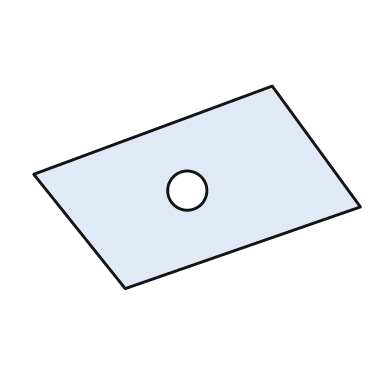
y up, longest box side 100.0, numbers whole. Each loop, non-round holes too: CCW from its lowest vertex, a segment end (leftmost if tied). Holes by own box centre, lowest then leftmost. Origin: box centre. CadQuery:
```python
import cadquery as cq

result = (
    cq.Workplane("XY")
    .moveTo(-22.0, -31.0)
    .lineTo(50.0, -6.0)
    .lineTo(23.0, 31.0)
    .lineTo(-50.0, 4.0)
    .close()
    .moveTo(-3.0, -1.0)
    .circle(6.0)
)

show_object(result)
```